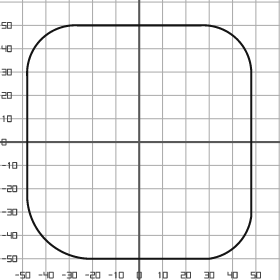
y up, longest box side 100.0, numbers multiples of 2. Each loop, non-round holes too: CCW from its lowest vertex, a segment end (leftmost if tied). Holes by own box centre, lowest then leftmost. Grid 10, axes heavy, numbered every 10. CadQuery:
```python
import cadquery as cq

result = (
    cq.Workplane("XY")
    .moveTo(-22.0, -50.0)
    .lineTo(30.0, -50.0)
    .threePointArc((42.0, -44.0), (48.0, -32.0))
    .lineTo(48.0, 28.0)
    .threePointArc((42.0, 44.0), (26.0, 50.0))
    .lineTo(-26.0, 50.0)
    .threePointArc((-42.0, 44.0), (-48.0, 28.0))
    .lineTo(-48.0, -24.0)
    .threePointArc((-40.0, -42.0), (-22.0, -50.0))
    .close()
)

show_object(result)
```